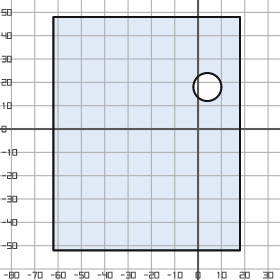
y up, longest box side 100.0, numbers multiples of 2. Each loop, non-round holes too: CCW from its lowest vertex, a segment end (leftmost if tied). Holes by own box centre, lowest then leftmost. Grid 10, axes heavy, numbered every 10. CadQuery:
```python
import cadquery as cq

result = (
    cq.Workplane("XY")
    .moveTo(-62.0, -52.0)
    .lineTo(18.0, -52.0)
    .lineTo(18.0, 48.0)
    .lineTo(-62.0, 48.0)
    .close()
    .moveTo(4.0, 18.0)
    .circle(6.0)
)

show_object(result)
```